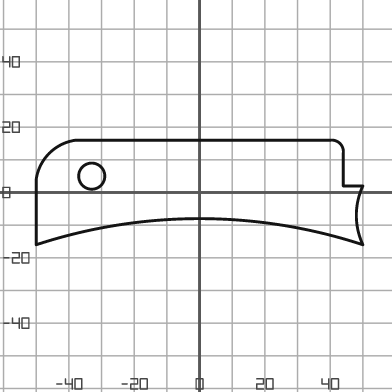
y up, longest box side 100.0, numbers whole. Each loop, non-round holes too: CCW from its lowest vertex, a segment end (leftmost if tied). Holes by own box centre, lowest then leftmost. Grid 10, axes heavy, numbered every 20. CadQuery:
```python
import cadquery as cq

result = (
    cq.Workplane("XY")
    .moveTo(-50.0, -16.0)
    .threePointArc((0.0, -8.0), (50.0, -16.0))
    .threePointArc((48.0, -7.0), (50.0, 2.0))
    .lineTo(44.0, 2.0)
    .lineTo(44.0, 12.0)
    .threePointArc((43.0, 15.0), (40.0, 16.0))
    .lineTo(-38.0, 16.0)
    .threePointArc((-46.0, 12.0), (-50.0, 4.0))
    .close()
    .moveTo(-33.0, 5.0)
    .circle(4.0)
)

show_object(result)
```